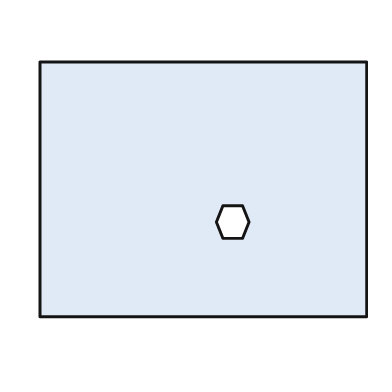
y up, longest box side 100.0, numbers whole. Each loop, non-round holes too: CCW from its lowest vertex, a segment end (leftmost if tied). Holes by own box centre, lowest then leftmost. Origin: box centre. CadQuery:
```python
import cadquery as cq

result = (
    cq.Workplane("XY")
    .moveTo(-50.0, -39.0)
    .lineTo(50.0, -39.0)
    .lineTo(50.0, 39.0)
    .lineTo(-50.0, 39.0)
    .close()
    .moveTo(6.0, -15.0)
    .lineTo(12.0, -15.0)
    .lineTo(14.0, -10.0)
    .lineTo(12.0, -5.0)
    .lineTo(6.0, -5.0)
    .lineTo(4.0, -10.0)
    .close()
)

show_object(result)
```